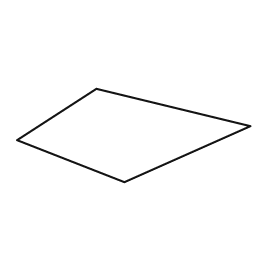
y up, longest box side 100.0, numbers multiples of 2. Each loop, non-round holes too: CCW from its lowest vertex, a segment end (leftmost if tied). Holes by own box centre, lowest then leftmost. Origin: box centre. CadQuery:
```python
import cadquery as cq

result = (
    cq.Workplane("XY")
    .moveTo(-4.0, -20.0)
    .lineTo(50.0, 4.0)
    .lineTo(-16.0, 20.0)
    .lineTo(-50.0, -2.0)
    .close()
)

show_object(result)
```